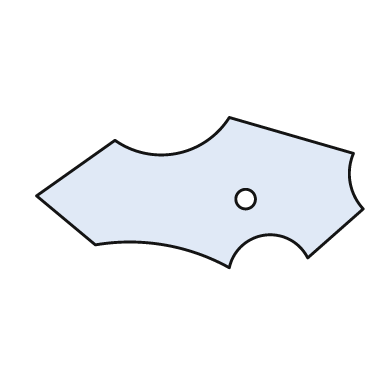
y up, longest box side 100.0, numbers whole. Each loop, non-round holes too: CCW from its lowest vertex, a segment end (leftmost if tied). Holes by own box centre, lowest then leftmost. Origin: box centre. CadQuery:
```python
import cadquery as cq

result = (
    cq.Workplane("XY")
    .moveTo(9.0, -23.0)
    .threePointArc((20.0, -13.0), (33.0, -20.0))
    .lineTo(50.0, -5.0)
    .threePointArc((46.0, 3.0), (47.0, 12.0))
    .lineTo(9.0, 23.0)
    .threePointArc((-7.0, 12.0), (-26.0, 16.0))
    .lineTo(-50.0, -1.0)
    .lineTo(-32.0, -16.0)
    .threePointArc((-11.0, -16.0), (9.0, -23.0))
    .close()
    .moveTo(14.0, -2.0)
    .circle(3.0)
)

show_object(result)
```